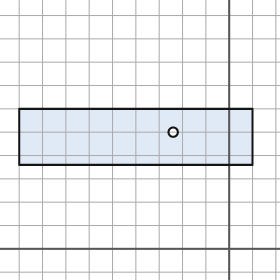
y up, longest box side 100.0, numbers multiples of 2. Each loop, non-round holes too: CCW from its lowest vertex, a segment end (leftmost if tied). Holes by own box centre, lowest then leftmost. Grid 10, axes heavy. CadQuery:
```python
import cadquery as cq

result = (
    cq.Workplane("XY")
    .moveTo(-90.0, 36.0)
    .lineTo(10.0, 36.0)
    .lineTo(10.0, 60.0)
    .lineTo(-90.0, 60.0)
    .close()
    .moveTo(-24.0, 50.0)
    .circle(2.0)
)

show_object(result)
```